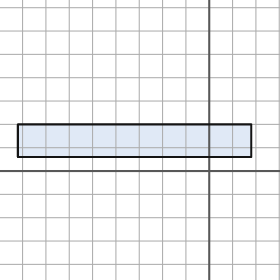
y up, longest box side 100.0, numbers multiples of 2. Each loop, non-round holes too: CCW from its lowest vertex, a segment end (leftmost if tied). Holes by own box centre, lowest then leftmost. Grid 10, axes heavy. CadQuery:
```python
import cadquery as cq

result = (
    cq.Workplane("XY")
    .moveTo(-82.0, 6.0)
    .lineTo(18.0, 6.0)
    .lineTo(18.0, 20.0)
    .lineTo(-82.0, 20.0)
    .close()
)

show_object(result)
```